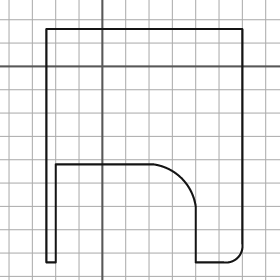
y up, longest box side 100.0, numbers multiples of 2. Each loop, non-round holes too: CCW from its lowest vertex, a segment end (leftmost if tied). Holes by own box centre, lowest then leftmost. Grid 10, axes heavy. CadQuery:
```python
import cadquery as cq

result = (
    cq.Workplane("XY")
    .moveTo(-24.0, -84.0)
    .lineTo(-20.0, -84.0)
    .lineTo(-20.0, -42.0)
    .lineTo(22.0, -42.0)
    .threePointArc((34.0, -48.0), (40.0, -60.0))
    .lineTo(40.0, -84.0)
    .lineTo(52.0, -84.0)
    .threePointArc((58.0, -82.0), (60.0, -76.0))
    .lineTo(60.0, 16.0)
    .lineTo(-24.0, 16.0)
    .close()
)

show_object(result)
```